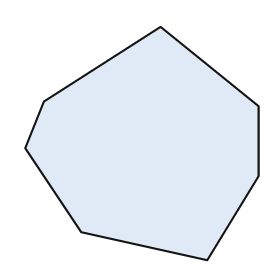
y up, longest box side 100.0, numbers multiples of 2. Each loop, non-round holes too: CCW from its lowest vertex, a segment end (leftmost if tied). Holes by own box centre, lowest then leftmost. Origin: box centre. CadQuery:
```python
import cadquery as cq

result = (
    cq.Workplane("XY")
    .moveTo(28.0, -50.0)
    .lineTo(50.0, -14.0)
    .lineTo(50.0, 16.0)
    .lineTo(8.0, 50.0)
    .lineTo(-42.0, 18.0)
    .lineTo(-50.0, -2.0)
    .lineTo(-26.0, -38.0)
    .close()
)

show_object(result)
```